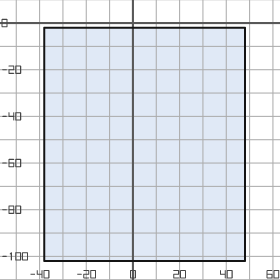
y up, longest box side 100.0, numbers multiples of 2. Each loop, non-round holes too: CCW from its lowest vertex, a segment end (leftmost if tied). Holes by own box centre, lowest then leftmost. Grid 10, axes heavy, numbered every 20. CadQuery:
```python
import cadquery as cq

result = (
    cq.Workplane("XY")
    .moveTo(-38.0, -102.0)
    .lineTo(48.0, -102.0)
    .lineTo(48.0, -2.0)
    .lineTo(-38.0, -2.0)
    .close()
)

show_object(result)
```